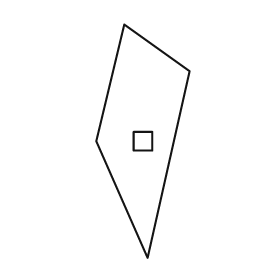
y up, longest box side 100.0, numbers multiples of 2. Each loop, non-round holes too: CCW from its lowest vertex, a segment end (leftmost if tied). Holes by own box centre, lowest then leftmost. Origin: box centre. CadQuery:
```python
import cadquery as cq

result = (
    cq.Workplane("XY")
    .moveTo(2.0, -50.0)
    .lineTo(20.0, 30.0)
    .lineTo(-8.0, 50.0)
    .lineTo(-20.0, 0.0)
    .close()
    .moveTo(-4.0, -4.0)
    .lineTo(4.0, -4.0)
    .lineTo(4.0, 4.0)
    .lineTo(-4.0, 4.0)
    .close()
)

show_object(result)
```